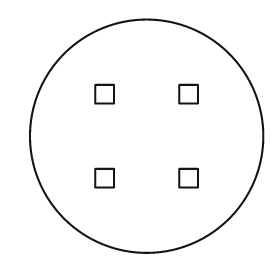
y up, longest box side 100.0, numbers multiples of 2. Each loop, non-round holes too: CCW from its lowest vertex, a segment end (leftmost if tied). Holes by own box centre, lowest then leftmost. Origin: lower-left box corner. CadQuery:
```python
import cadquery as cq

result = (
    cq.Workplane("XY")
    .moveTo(50.0, 50.0)
    .circle(50.0)
    .moveTo(28.0, 28.0)
    .lineTo(36.0, 28.0)
    .lineTo(36.0, 36.0)
    .lineTo(28.0, 36.0)
    .close()
    .moveTo(64.0, 28.0)
    .lineTo(72.0, 28.0)
    .lineTo(72.0, 36.0)
    .lineTo(64.0, 36.0)
    .close()
    .moveTo(28.0, 64.0)
    .lineTo(36.0, 64.0)
    .lineTo(36.0, 72.0)
    .lineTo(28.0, 72.0)
    .close()
    .moveTo(64.0, 64.0)
    .lineTo(72.0, 64.0)
    .lineTo(72.0, 72.0)
    .lineTo(64.0, 72.0)
    .close()
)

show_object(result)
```